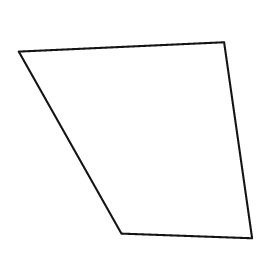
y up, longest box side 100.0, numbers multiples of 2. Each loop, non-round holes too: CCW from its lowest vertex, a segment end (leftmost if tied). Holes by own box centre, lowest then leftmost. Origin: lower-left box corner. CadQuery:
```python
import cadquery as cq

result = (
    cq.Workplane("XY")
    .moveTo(100.0, 0.0)
    .lineTo(88.0, 84.0)
    .lineTo(0.0, 80.0)
    .lineTo(44.0, 2.0)
    .close()
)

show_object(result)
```